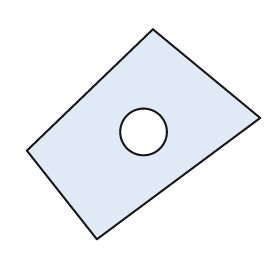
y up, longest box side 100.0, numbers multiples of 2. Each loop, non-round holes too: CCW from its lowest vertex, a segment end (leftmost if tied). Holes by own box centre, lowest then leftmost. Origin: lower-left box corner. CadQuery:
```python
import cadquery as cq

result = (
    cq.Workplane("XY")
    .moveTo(30.0, 0.0)
    .lineTo(100.0, 52.0)
    .lineTo(54.0, 90.0)
    .lineTo(0.0, 38.0)
    .close()
    .moveTo(50.0, 46.0)
    .circle(10.0)
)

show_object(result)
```